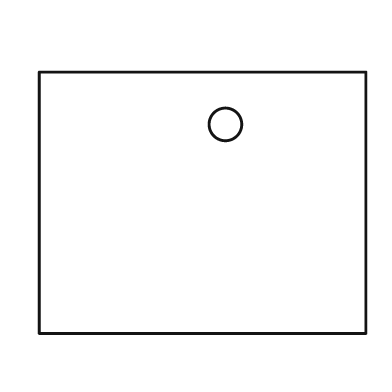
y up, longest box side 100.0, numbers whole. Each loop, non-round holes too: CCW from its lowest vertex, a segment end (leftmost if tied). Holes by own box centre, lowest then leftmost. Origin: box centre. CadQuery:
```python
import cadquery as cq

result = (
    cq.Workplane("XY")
    .moveTo(-50.0, -40.0)
    .lineTo(50.0, -40.0)
    .lineTo(50.0, 40.0)
    .lineTo(-50.0, 40.0)
    .close()
    .moveTo(7.0, 24.0)
    .circle(5.0)
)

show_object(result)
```